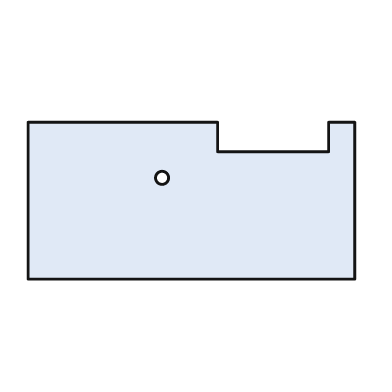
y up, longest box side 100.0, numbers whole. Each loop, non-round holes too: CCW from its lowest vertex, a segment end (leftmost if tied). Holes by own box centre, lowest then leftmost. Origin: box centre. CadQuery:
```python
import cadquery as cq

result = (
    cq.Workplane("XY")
    .moveTo(-50.0, -24.0)
    .lineTo(50.0, -24.0)
    .lineTo(50.0, 24.0)
    .lineTo(42.0, 24.0)
    .lineTo(42.0, 15.0)
    .lineTo(8.0, 15.0)
    .lineTo(8.0, 24.0)
    .lineTo(-50.0, 24.0)
    .close()
    .moveTo(-9.0, 7.0)
    .circle(2.0)
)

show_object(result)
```